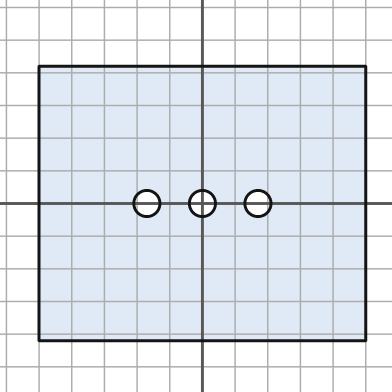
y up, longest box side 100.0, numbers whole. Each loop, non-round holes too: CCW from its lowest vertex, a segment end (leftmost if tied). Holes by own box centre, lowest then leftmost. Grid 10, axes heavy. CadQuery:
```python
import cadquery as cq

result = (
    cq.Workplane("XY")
    .moveTo(-50.0, -42.0)
    .lineTo(50.0, -42.0)
    .lineTo(50.0, 42.0)
    .lineTo(-50.0, 42.0)
    .close()
    .moveTo(-17.0, 0.0)
    .circle(4.0)
    .moveTo(0.0, 0.0)
    .circle(4.0)
    .moveTo(17.0, 0.0)
    .circle(4.0)
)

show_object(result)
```